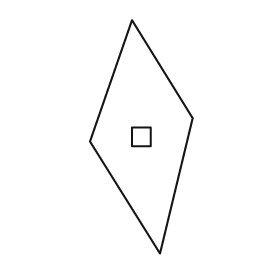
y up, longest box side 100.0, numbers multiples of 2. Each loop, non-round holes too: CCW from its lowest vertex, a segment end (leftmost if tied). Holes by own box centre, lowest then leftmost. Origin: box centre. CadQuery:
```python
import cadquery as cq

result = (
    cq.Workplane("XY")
    .moveTo(8.0, -50.0)
    .lineTo(22.0, 8.0)
    .lineTo(-4.0, 50.0)
    .lineTo(-22.0, -2.0)
    .close()
    .moveTo(-4.0, -4.0)
    .lineTo(4.0, -4.0)
    .lineTo(4.0, 4.0)
    .lineTo(-4.0, 4.0)
    .close()
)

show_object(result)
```